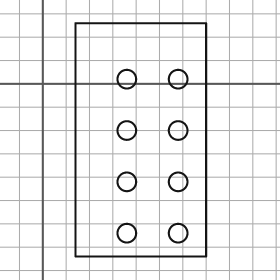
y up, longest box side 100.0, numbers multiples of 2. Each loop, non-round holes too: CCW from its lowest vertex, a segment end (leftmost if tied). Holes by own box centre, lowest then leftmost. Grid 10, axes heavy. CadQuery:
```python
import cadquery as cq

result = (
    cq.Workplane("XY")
    .moveTo(14.0, -74.0)
    .lineTo(70.0, -74.0)
    .lineTo(70.0, 26.0)
    .lineTo(14.0, 26.0)
    .close()
    .moveTo(36.0, -64.0)
    .circle(4.0)
    .moveTo(58.0, -64.0)
    .circle(4.0)
    .moveTo(36.0, -42.0)
    .circle(4.0)
    .moveTo(58.0, -42.0)
    .circle(4.0)
    .moveTo(36.0, -20.0)
    .circle(4.0)
    .moveTo(58.0, -20.0)
    .circle(4.0)
    .moveTo(36.0, 2.0)
    .circle(4.0)
    .moveTo(58.0, 2.0)
    .circle(4.0)
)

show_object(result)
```